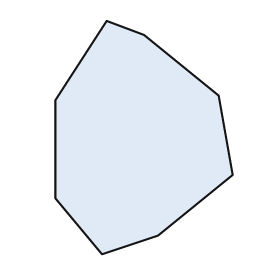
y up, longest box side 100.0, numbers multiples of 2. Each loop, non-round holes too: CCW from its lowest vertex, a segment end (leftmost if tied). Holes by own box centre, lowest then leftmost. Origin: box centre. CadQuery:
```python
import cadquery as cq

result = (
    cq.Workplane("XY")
    .moveTo(-18.0, -50.0)
    .lineTo(6.0, -42.0)
    .lineTo(38.0, -16.0)
    .lineTo(32.0, 18.0)
    .lineTo(0.0, 44.0)
    .lineTo(-16.0, 50.0)
    .lineTo(-38.0, 16.0)
    .lineTo(-38.0, -26.0)
    .close()
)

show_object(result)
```